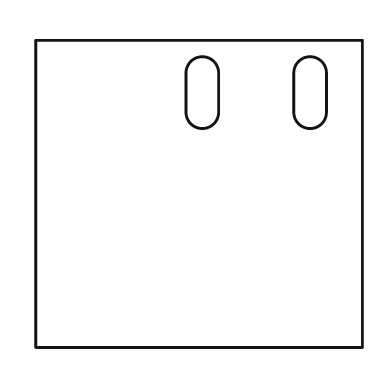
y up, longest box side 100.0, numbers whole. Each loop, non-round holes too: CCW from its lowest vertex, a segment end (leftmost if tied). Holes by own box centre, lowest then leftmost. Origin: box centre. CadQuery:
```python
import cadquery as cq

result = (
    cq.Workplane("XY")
    .moveTo(-50.0, -47.0)
    .lineTo(50.0, -47.0)
    .lineTo(50.0, 47.0)
    .lineTo(-50.0, 47.0)
    .close()
    .moveTo(-4.0, 25.0)
    .threePointArc((1.0, 20.0), (6.0, 25.0))
    .lineTo(6.0, 37.0)
    .threePointArc((1.0, 42.0), (-4.0, 37.0))
    .close()
    .moveTo(29.0, 25.0)
    .threePointArc((34.0, 20.0), (39.0, 25.0))
    .lineTo(39.0, 37.0)
    .threePointArc((34.0, 42.0), (29.0, 37.0))
    .close()
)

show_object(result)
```